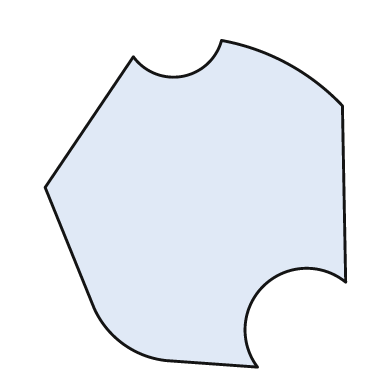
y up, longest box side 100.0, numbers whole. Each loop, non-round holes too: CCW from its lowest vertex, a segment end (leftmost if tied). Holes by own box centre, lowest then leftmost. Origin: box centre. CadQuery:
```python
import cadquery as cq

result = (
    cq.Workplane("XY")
    .moveTo(19.0, -50.0)
    .threePointArc((21.0, -25.0), (46.0, -24.0))
    .lineTo(45.0, 30.0)
    .threePointArc((28.0, 43.0), (8.0, 50.0))
    .threePointArc((-4.0, 39.0), (-19.0, 45.0))
    .lineTo(-46.0, 5.0)
    .lineTo(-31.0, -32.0)
    .threePointArc((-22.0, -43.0), (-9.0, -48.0))
    .close()
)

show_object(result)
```